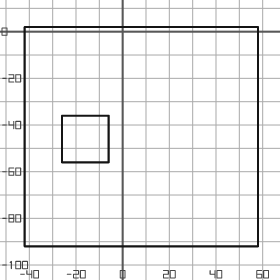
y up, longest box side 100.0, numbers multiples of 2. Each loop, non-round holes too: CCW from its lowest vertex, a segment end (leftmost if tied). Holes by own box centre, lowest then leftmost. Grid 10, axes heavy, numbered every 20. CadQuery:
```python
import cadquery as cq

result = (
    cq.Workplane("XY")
    .moveTo(-42.0, -92.0)
    .lineTo(58.0, -92.0)
    .lineTo(58.0, 2.0)
    .lineTo(-42.0, 2.0)
    .close()
    .moveTo(-26.0, -56.0)
    .lineTo(-6.0, -56.0)
    .lineTo(-6.0, -36.0)
    .lineTo(-26.0, -36.0)
    .close()
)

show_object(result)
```